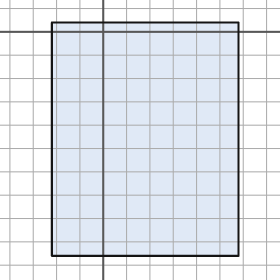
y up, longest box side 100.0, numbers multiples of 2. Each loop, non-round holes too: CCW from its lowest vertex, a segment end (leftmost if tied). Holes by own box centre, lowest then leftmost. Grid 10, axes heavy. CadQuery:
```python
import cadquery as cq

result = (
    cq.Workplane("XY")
    .moveTo(-22.0, -96.0)
    .lineTo(58.0, -96.0)
    .lineTo(58.0, 4.0)
    .lineTo(-22.0, 4.0)
    .close()
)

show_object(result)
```